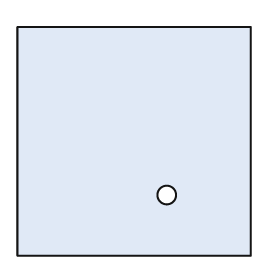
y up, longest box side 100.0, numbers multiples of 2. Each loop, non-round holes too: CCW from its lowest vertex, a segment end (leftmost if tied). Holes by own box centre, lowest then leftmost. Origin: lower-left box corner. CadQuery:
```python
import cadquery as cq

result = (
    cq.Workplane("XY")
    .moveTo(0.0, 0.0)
    .lineTo(100.0, 0.0)
    .lineTo(100.0, 98.0)
    .lineTo(0.0, 98.0)
    .close()
    .moveTo(64.0, 26.0)
    .circle(4.0)
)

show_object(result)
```